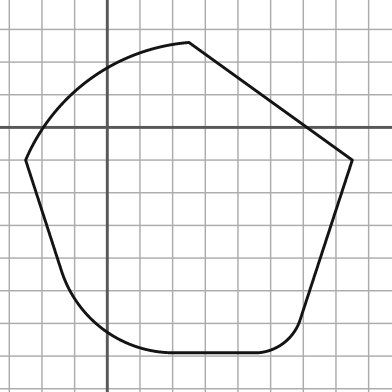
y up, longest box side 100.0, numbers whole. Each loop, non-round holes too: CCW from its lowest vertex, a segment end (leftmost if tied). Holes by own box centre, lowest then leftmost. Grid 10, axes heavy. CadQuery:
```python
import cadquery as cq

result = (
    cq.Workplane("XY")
    .moveTo(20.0, -69.0)
    .lineTo(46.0, -69.0)
    .threePointArc((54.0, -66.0), (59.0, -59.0))
    .lineTo(75.0, -10.0)
    .lineTo(25.0, 26.0)
    .threePointArc((-5.0, 15.0), (-25.0, -10.0))
    .lineTo(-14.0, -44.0)
    .threePointArc((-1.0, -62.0), (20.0, -69.0))
    .close()
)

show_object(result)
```